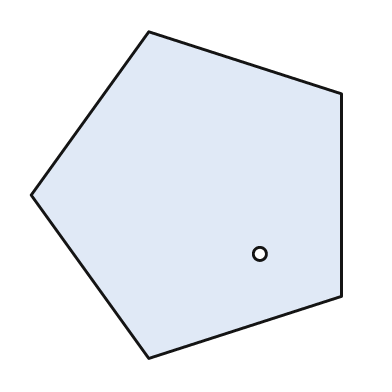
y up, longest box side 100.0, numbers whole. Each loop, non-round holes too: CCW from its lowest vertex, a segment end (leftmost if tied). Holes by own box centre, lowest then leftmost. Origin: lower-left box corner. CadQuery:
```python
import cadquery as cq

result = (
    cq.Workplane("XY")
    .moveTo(36.0, 0.0)
    .lineTo(95.0, 19.0)
    .lineTo(95.0, 81.0)
    .lineTo(36.0, 100.0)
    .lineTo(0.0, 50.0)
    .close()
    .moveTo(70.0, 32.0)
    .circle(2.0)
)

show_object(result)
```